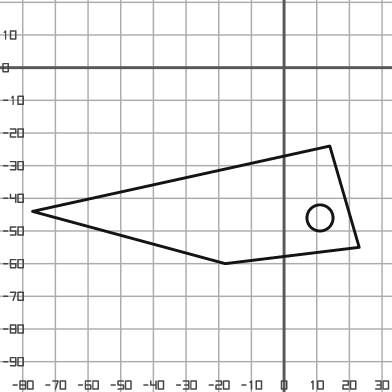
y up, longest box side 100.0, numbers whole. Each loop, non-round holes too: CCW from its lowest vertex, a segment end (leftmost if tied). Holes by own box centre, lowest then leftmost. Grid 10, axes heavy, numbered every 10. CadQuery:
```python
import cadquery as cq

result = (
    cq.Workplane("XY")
    .moveTo(-18.0, -60.0)
    .lineTo(23.0, -55.0)
    .lineTo(14.0, -24.0)
    .lineTo(-77.0, -44.0)
    .close()
    .moveTo(11.0, -46.0)
    .circle(4.0)
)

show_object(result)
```